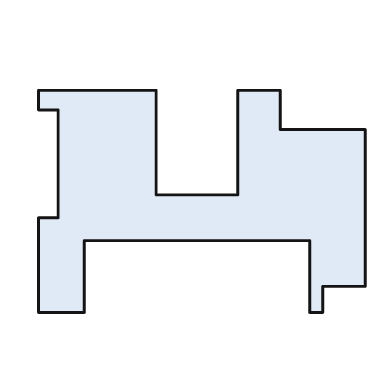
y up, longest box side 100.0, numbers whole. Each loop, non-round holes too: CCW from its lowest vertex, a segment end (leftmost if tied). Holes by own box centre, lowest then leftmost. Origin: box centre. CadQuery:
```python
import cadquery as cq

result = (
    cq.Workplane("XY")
    .moveTo(-50.0, -34.0)
    .lineTo(-36.0, -34.0)
    .lineTo(-36.0, -12.0)
    .lineTo(33.0, -12.0)
    .lineTo(33.0, -34.0)
    .lineTo(37.0, -34.0)
    .lineTo(37.0, -26.0)
    .lineTo(50.0, -26.0)
    .lineTo(50.0, 22.0)
    .lineTo(24.0, 22.0)
    .lineTo(24.0, 34.0)
    .lineTo(11.0, 34.0)
    .lineTo(11.0, 2.0)
    .lineTo(-14.0, 2.0)
    .lineTo(-14.0, 34.0)
    .lineTo(-50.0, 34.0)
    .lineTo(-50.0, 28.0)
    .lineTo(-44.0, 28.0)
    .lineTo(-44.0, -5.0)
    .lineTo(-50.0, -5.0)
    .close()
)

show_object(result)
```